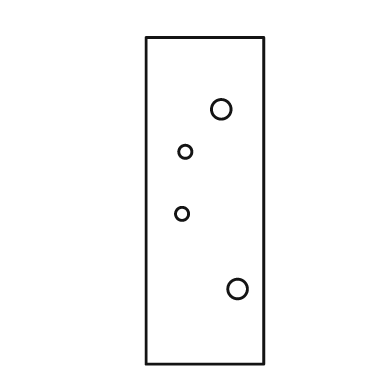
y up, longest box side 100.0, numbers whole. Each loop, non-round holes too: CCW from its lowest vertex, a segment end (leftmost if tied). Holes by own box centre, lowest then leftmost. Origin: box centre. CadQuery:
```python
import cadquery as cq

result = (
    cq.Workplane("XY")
    .moveTo(-18.0, -50.0)
    .lineTo(18.0, -50.0)
    .lineTo(18.0, 50.0)
    .lineTo(-18.0, 50.0)
    .close()
    .moveTo(10.0, -27.0)
    .circle(3.0)
    .moveTo(-7.0, -4.0)
    .circle(2.0)
    .moveTo(-6.0, 15.0)
    .circle(2.0)
    .moveTo(5.0, 28.0)
    .circle(3.0)
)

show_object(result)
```